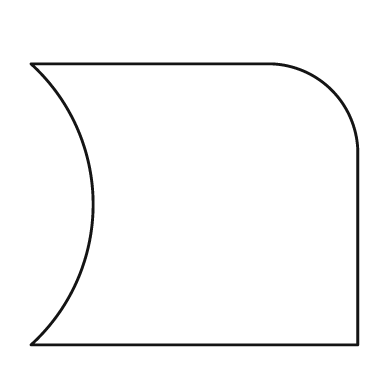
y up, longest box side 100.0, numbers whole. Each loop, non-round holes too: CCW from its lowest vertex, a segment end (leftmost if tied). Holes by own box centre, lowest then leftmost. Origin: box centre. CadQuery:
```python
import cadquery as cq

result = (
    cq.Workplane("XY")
    .moveTo(-50.0, -43.0)
    .lineTo(50.0, -43.0)
    .lineTo(50.0, 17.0)
    .threePointArc((42.0, 35.0), (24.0, 43.0))
    .lineTo(-50.0, 43.0)
    .threePointArc((-31.0, 0.0), (-50.0, -43.0))
    .close()
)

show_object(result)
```